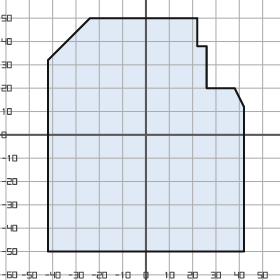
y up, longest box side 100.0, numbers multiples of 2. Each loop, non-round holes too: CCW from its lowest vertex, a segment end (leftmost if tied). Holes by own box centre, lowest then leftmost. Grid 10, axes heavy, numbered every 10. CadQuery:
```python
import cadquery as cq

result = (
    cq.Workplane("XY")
    .moveTo(-42.0, -50.0)
    .lineTo(42.0, -50.0)
    .lineTo(42.0, 12.0)
    .lineTo(38.0, 20.0)
    .lineTo(26.0, 20.0)
    .lineTo(26.0, 38.0)
    .lineTo(22.0, 38.0)
    .lineTo(22.0, 50.0)
    .lineTo(-24.0, 50.0)
    .lineTo(-42.0, 32.0)
    .close()
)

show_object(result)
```